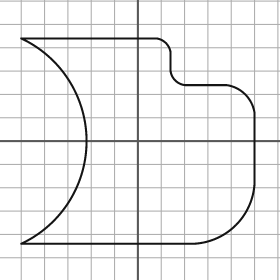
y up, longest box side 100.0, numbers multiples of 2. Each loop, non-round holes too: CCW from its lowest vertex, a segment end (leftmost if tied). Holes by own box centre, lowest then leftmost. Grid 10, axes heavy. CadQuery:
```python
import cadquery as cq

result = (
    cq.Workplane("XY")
    .moveTo(-50.0, -44.0)
    .lineTo(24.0, -44.0)
    .threePointArc((42.0, -36.0), (50.0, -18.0))
    .lineTo(50.0, 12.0)
    .threePointArc((46.0, 20.0), (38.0, 24.0))
    .lineTo(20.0, 24.0)
    .threePointArc((16.0, 26.0), (14.0, 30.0))
    .lineTo(14.0, 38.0)
    .threePointArc((12.0, 42.0), (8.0, 44.0))
    .lineTo(-50.0, 44.0)
    .threePointArc((-22.0, 0.0), (-50.0, -44.0))
    .close()
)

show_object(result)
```